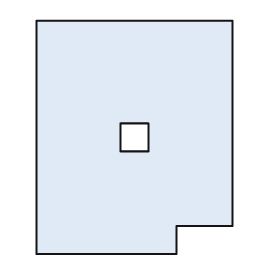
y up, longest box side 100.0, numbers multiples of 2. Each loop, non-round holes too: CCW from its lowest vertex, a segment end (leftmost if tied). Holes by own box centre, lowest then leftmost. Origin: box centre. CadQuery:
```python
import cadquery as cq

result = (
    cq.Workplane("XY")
    .moveTo(-42.0, -50.0)
    .lineTo(18.0, -50.0)
    .lineTo(18.0, -38.0)
    .lineTo(42.0, -38.0)
    .lineTo(42.0, 50.0)
    .lineTo(-42.0, 50.0)
    .close()
    .moveTo(-6.0, -6.0)
    .lineTo(6.0, -6.0)
    .lineTo(6.0, 6.0)
    .lineTo(-6.0, 6.0)
    .close()
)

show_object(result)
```